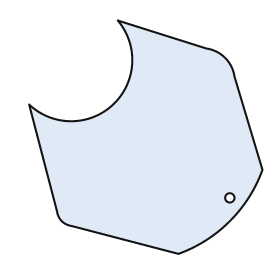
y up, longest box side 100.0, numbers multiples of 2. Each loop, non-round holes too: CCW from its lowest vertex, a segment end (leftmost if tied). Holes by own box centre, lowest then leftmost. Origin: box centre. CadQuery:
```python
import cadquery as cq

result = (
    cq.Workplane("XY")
    .moveTo(14.0, -50.0)
    .threePointArc((36.0, -36.0), (50.0, -14.0))
    .lineTo(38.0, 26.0)
    .threePointArc((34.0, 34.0), (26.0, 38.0))
    .lineTo(-12.0, 50.0)
    .threePointArc((-14.0, 14.0), (-50.0, 14.0))
    .lineTo(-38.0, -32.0)
    .threePointArc((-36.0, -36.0), (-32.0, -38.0))
    .close()
    .moveTo(36.0, -26.0)
    .circle(2.0)
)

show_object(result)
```